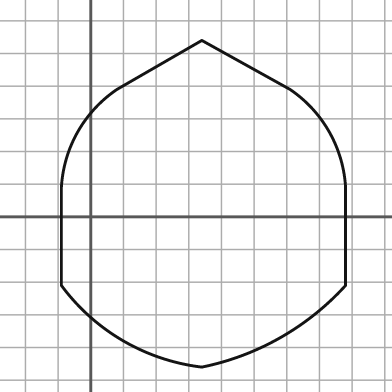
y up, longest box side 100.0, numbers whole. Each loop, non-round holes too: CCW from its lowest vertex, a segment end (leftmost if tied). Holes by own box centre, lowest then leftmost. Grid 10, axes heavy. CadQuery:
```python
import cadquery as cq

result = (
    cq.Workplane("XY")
    .moveTo(34.0, -46.0)
    .threePointArc((58.0, -37.0), (78.0, -21.0))
    .lineTo(78.0, 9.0)
    .threePointArc((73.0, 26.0), (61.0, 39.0))
    .lineTo(34.0, 54.0)
    .lineTo(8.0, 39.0)
    .threePointArc((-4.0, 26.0), (-9.0, 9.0))
    .lineTo(-9.0, -21.0)
    .threePointArc((10.0, -38.0), (34.0, -46.0))
    .close()
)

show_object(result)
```